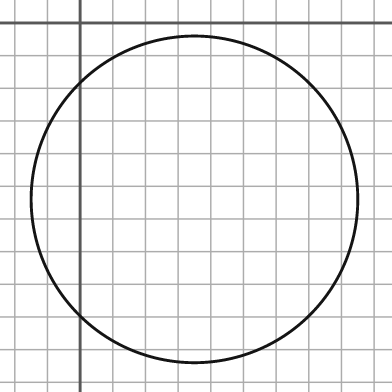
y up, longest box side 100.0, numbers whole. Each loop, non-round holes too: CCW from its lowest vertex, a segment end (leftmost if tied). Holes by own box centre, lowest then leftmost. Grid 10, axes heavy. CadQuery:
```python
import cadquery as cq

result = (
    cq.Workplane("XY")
    .moveTo(35.0, -54.0)
    .circle(50.0)
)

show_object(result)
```